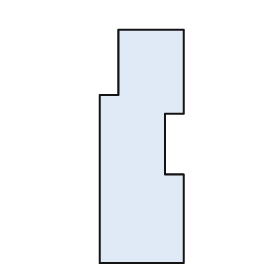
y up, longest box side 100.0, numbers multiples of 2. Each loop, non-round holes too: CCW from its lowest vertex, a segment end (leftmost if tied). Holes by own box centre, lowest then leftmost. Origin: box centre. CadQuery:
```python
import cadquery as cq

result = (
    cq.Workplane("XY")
    .moveTo(-18.0, -50.0)
    .lineTo(18.0, -50.0)
    .lineTo(18.0, -12.0)
    .lineTo(10.0, -12.0)
    .lineTo(10.0, 14.0)
    .lineTo(18.0, 14.0)
    .lineTo(18.0, 50.0)
    .lineTo(-10.0, 50.0)
    .lineTo(-10.0, 22.0)
    .lineTo(-18.0, 22.0)
    .close()
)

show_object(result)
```